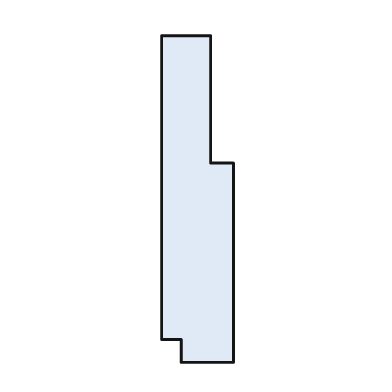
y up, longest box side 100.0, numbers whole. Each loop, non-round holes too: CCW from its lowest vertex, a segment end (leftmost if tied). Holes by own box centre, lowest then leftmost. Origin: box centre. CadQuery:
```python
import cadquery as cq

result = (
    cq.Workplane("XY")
    .moveTo(-5.0, -50.0)
    .lineTo(11.0, -50.0)
    .lineTo(11.0, 11.0)
    .lineTo(4.0, 11.0)
    .lineTo(4.0, 50.0)
    .lineTo(-11.0, 50.0)
    .lineTo(-11.0, -43.0)
    .lineTo(-5.0, -43.0)
    .close()
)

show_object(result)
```